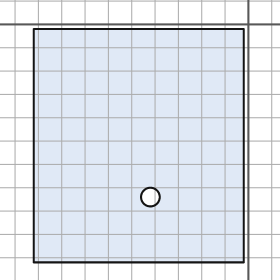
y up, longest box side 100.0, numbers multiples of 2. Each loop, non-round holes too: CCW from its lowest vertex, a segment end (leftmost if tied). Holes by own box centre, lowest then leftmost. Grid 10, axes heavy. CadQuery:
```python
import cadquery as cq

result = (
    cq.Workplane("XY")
    .moveTo(-92.0, -102.0)
    .lineTo(-2.0, -102.0)
    .lineTo(-2.0, -2.0)
    .lineTo(-92.0, -2.0)
    .close()
    .moveTo(-42.0, -74.0)
    .circle(4.0)
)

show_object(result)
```